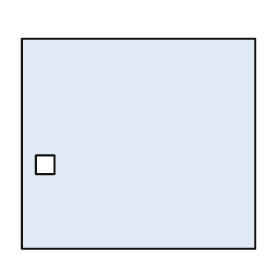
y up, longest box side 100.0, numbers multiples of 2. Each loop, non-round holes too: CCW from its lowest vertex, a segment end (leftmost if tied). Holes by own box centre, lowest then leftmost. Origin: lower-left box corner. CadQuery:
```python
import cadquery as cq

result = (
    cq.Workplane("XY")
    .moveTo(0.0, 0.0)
    .lineTo(100.0, 0.0)
    .lineTo(100.0, 90.0)
    .lineTo(0.0, 90.0)
    .close()
    .moveTo(6.0, 32.0)
    .lineTo(14.0, 32.0)
    .lineTo(14.0, 40.0)
    .lineTo(6.0, 40.0)
    .close()
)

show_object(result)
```